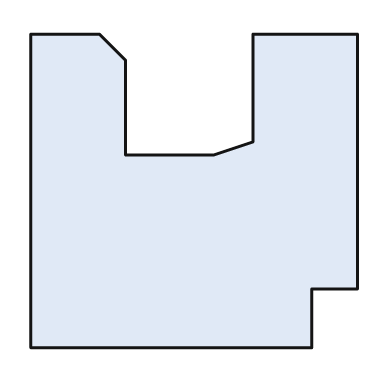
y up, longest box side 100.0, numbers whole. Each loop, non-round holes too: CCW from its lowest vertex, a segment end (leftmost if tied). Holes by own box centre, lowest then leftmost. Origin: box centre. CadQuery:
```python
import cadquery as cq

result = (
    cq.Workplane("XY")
    .moveTo(-50.0, -48.0)
    .lineTo(36.0, -48.0)
    .lineTo(36.0, -30.0)
    .lineTo(50.0, -30.0)
    .lineTo(50.0, 48.0)
    .lineTo(18.0, 48.0)
    .lineTo(18.0, 15.0)
    .lineTo(6.0, 11.0)
    .lineTo(-21.0, 11.0)
    .lineTo(-21.0, 40.0)
    .lineTo(-29.0, 48.0)
    .lineTo(-50.0, 48.0)
    .close()
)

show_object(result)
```